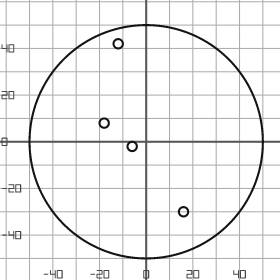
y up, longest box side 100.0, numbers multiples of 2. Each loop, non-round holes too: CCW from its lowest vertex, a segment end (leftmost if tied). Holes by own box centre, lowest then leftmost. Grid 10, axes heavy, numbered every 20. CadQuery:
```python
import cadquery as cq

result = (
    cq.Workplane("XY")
    .moveTo(0.0, 0.0)
    .circle(50.0)
    .moveTo(16.0, -30.0)
    .circle(2.0)
    .moveTo(-6.0, -2.0)
    .circle(2.0)
    .moveTo(-18.0, 8.0)
    .circle(2.0)
    .moveTo(-12.0, 42.0)
    .circle(2.0)
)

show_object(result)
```